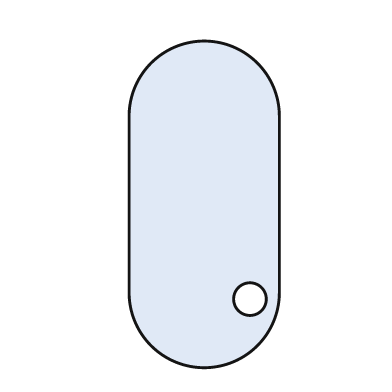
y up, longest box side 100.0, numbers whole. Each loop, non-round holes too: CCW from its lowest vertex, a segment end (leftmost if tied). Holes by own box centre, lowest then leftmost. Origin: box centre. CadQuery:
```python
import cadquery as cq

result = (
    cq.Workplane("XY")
    .moveTo(-23.0, -27.0)
    .threePointArc((0.0, -50.0), (23.0, -27.0))
    .lineTo(23.0, 27.0)
    .threePointArc((0.0, 50.0), (-23.0, 27.0))
    .close()
    .moveTo(14.0, -29.0)
    .circle(5.0)
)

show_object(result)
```